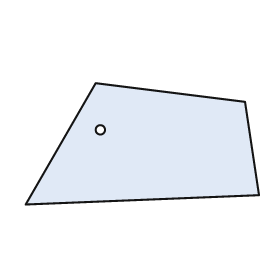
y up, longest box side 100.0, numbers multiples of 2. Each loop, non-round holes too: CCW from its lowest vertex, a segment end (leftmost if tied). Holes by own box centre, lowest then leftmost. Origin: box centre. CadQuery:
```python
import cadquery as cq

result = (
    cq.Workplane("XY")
    .moveTo(-50.0, -26.0)
    .lineTo(50.0, -22.0)
    .lineTo(44.0, 18.0)
    .lineTo(-20.0, 26.0)
    .close()
    .moveTo(-18.0, 6.0)
    .circle(2.0)
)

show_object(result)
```